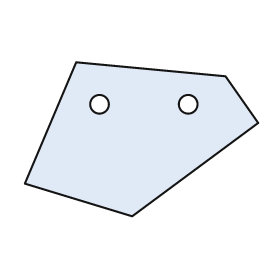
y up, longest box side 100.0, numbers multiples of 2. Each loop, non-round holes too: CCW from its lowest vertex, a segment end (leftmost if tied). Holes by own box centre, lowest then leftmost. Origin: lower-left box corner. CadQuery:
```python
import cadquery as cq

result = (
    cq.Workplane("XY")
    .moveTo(46.0, 0.0)
    .lineTo(100.0, 40.0)
    .lineTo(86.0, 60.0)
    .lineTo(22.0, 66.0)
    .lineTo(0.0, 14.0)
    .close()
    .moveTo(32.0, 48.0)
    .circle(4.0)
    .moveTo(70.0, 48.0)
    .circle(4.0)
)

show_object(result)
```